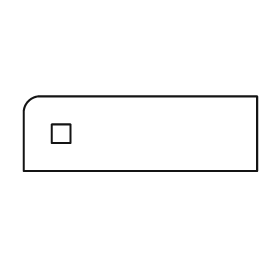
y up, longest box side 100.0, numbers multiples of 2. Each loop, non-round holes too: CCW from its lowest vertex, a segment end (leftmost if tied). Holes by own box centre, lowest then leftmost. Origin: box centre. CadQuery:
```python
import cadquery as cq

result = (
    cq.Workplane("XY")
    .moveTo(-50.0, -16.0)
    .lineTo(50.0, -16.0)
    .lineTo(50.0, 16.0)
    .lineTo(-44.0, 16.0)
    .threePointArc((-48.0, 14.0), (-50.0, 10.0))
    .close()
    .moveTo(-38.0, -4.0)
    .lineTo(-30.0, -4.0)
    .lineTo(-30.0, 4.0)
    .lineTo(-38.0, 4.0)
    .close()
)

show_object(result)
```